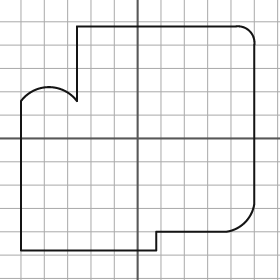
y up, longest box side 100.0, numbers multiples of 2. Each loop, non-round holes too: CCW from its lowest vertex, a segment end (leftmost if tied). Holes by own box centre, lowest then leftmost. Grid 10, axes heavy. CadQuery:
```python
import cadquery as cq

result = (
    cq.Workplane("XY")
    .moveTo(-50.0, -48.0)
    .lineTo(8.0, -48.0)
    .lineTo(8.0, -40.0)
    .lineTo(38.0, -40.0)
    .threePointArc((46.0, -36.0), (50.0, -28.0))
    .lineTo(50.0, 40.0)
    .threePointArc((48.0, 46.0), (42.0, 48.0))
    .lineTo(-26.0, 48.0)
    .lineTo(-26.0, 16.0)
    .threePointArc((-38.0, 22.0), (-50.0, 16.0))
    .close()
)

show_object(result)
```